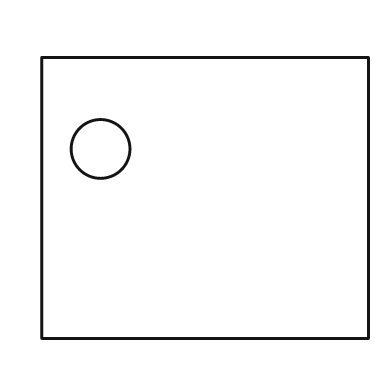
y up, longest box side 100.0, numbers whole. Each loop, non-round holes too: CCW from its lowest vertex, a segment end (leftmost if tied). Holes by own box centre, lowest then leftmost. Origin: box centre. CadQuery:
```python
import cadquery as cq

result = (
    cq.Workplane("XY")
    .moveTo(-50.0, -43.0)
    .lineTo(50.0, -43.0)
    .lineTo(50.0, 43.0)
    .lineTo(-50.0, 43.0)
    .close()
    .moveTo(-32.0, 15.0)
    .circle(9.0)
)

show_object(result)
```